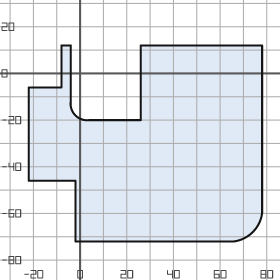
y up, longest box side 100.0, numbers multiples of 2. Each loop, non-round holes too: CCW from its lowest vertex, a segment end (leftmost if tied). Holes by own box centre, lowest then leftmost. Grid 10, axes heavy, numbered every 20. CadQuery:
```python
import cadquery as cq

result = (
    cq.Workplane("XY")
    .moveTo(-2.0, -72.0)
    .lineTo(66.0, -72.0)
    .threePointArc((74.0, -68.0), (78.0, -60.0))
    .lineTo(78.0, 12.0)
    .lineTo(26.0, 12.0)
    .lineTo(26.0, -20.0)
    .lineTo(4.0, -20.0)
    .threePointArc((-2.0, -18.0), (-4.0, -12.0))
    .lineTo(-4.0, 12.0)
    .lineTo(-8.0, 12.0)
    .lineTo(-8.0, -6.0)
    .lineTo(-22.0, -6.0)
    .lineTo(-22.0, -46.0)
    .lineTo(-2.0, -46.0)
    .close()
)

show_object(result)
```